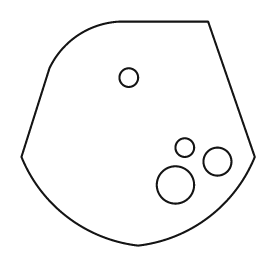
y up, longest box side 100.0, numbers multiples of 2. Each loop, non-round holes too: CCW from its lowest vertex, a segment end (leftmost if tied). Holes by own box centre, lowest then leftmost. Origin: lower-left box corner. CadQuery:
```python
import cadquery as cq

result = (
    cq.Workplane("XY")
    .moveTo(50.0, 0.0)
    .threePointArc((80.0, 12.0), (100.0, 38.0))
    .lineTo(80.0, 96.0)
    .lineTo(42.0, 96.0)
    .threePointArc((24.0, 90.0), (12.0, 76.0))
    .lineTo(0.0, 38.0)
    .threePointArc((20.0, 12.0), (50.0, 0.0))
    .close()
    .moveTo(66.0, 26.0)
    .circle(8.0)
    .moveTo(84.0, 36.0)
    .circle(6.0)
    .moveTo(70.0, 42.0)
    .circle(4.0)
    .moveTo(46.0, 72.0)
    .circle(4.0)
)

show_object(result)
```